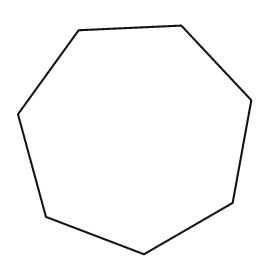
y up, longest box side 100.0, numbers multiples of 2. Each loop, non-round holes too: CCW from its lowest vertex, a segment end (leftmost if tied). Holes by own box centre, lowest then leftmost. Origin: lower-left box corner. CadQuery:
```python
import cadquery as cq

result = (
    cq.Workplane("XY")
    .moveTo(54.0, 0.0)
    .lineTo(92.0, 22.0)
    .lineTo(100.0, 66.0)
    .lineTo(70.0, 98.0)
    .lineTo(26.0, 96.0)
    .lineTo(0.0, 60.0)
    .lineTo(12.0, 16.0)
    .close()
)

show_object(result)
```